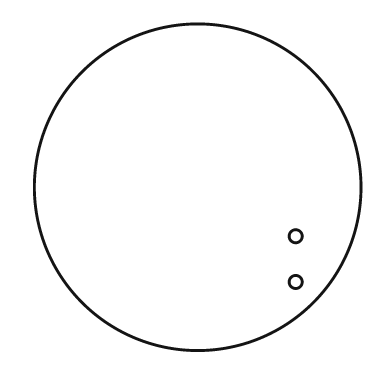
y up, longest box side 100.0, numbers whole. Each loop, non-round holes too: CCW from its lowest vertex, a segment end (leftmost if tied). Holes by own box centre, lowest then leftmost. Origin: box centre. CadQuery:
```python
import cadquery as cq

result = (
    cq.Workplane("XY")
    .moveTo(0.0, 0.0)
    .circle(50.0)
    .moveTo(30.0, -29.0)
    .circle(2.0)
    .moveTo(30.0, -15.0)
    .circle(2.0)
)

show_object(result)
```